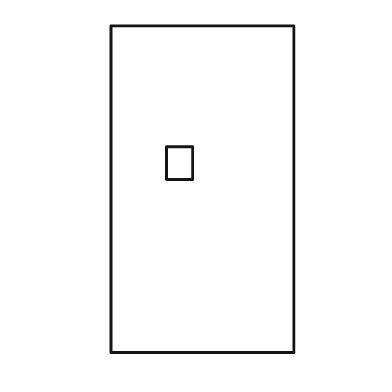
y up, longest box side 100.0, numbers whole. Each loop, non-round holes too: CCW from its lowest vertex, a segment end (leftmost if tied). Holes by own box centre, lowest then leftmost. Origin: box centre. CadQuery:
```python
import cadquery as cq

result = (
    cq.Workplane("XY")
    .moveTo(-28.0, -50.0)
    .lineTo(28.0, -50.0)
    .lineTo(28.0, 50.0)
    .lineTo(-28.0, 50.0)
    .close()
    .moveTo(-11.0, 3.0)
    .lineTo(-3.0, 3.0)
    .lineTo(-3.0, 13.0)
    .lineTo(-11.0, 13.0)
    .close()
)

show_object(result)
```